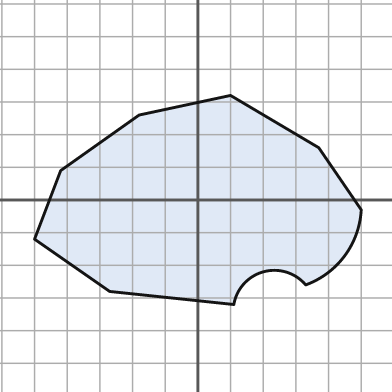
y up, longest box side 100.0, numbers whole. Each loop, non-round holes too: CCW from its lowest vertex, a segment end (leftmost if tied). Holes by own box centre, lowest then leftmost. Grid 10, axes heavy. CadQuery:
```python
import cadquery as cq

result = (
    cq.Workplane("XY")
    .moveTo(11.0, -32.0)
    .threePointArc((20.0, -22.0), (33.0, -26.0))
    .threePointArc((45.0, -17.0), (50.0, -3.0))
    .lineTo(37.0, 16.0)
    .lineTo(10.0, 32.0)
    .lineTo(-18.0, 26.0)
    .lineTo(-42.0, 9.0)
    .lineTo(-50.0, -12.0)
    .lineTo(-27.0, -28.0)
    .close()
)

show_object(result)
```